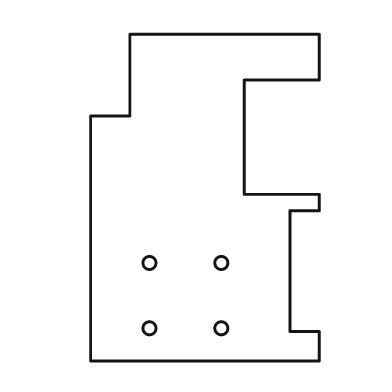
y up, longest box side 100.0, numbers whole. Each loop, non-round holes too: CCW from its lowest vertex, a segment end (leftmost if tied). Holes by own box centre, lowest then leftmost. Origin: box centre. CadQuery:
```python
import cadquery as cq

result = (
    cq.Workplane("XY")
    .moveTo(-35.0, -50.0)
    .lineTo(35.0, -50.0)
    .lineTo(35.0, -41.0)
    .lineTo(26.0, -41.0)
    .lineTo(26.0, -4.0)
    .lineTo(35.0, -4.0)
    .lineTo(35.0, 1.0)
    .lineTo(12.0, 1.0)
    .lineTo(12.0, 36.0)
    .lineTo(35.0, 36.0)
    .lineTo(35.0, 50.0)
    .lineTo(-23.0, 50.0)
    .lineTo(-23.0, 25.0)
    .lineTo(-35.0, 25.0)
    .close()
    .moveTo(-17.0, -40.0)
    .circle(2.0)
    .moveTo(5.0, -40.0)
    .circle(2.0)
    .moveTo(-17.0, -20.0)
    .circle(2.0)
    .moveTo(5.0, -20.0)
    .circle(2.0)
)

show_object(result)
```